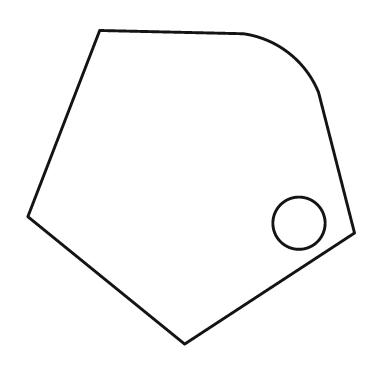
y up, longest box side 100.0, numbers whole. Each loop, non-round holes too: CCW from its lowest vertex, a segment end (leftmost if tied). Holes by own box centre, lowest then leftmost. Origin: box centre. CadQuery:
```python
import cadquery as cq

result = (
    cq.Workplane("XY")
    .moveTo(-2.0, -48.0)
    .lineTo(50.0, -14.0)
    .lineTo(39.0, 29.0)
    .threePointArc((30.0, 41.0), (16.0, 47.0))
    .lineTo(-28.0, 48.0)
    .lineTo(-50.0, -9.0)
    .close()
    .moveTo(33.0, -11.0)
    .circle(8.0)
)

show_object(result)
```